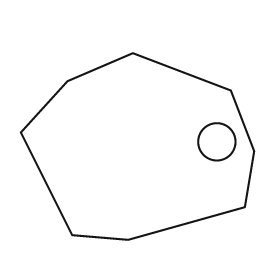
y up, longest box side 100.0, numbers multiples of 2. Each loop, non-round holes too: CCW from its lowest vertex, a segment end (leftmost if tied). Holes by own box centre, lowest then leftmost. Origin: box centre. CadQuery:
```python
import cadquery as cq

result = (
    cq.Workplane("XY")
    .moveTo(-4.0, -40.0)
    .lineTo(46.0, -26.0)
    .lineTo(50.0, -2.0)
    .lineTo(40.0, 24.0)
    .lineTo(-2.0, 40.0)
    .lineTo(-30.0, 28.0)
    .lineTo(-50.0, 6.0)
    .lineTo(-28.0, -38.0)
    .close()
    .moveTo(34.0, 2.0)
    .circle(8.0)
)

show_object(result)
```